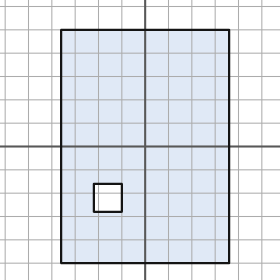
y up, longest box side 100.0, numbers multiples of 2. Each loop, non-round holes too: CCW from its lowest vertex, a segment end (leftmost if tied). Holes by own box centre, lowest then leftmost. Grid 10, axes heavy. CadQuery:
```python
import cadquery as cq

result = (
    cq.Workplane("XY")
    .moveTo(-36.0, -50.0)
    .lineTo(36.0, -50.0)
    .lineTo(36.0, 50.0)
    .lineTo(-36.0, 50.0)
    .close()
    .moveTo(-22.0, -28.0)
    .lineTo(-10.0, -28.0)
    .lineTo(-10.0, -16.0)
    .lineTo(-22.0, -16.0)
    .close()
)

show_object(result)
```